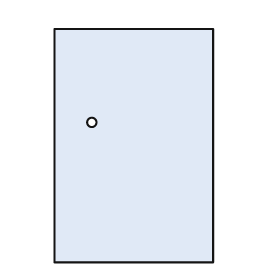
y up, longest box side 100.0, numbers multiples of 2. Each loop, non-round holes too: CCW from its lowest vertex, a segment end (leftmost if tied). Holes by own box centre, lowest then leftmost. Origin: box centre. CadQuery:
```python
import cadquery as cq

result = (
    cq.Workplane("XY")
    .moveTo(-34.0, -50.0)
    .lineTo(34.0, -50.0)
    .lineTo(34.0, 50.0)
    .lineTo(-34.0, 50.0)
    .close()
    .moveTo(-18.0, 10.0)
    .circle(2.0)
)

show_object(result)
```